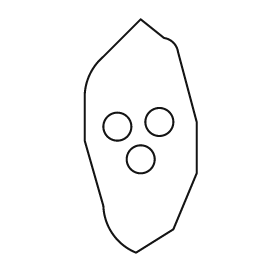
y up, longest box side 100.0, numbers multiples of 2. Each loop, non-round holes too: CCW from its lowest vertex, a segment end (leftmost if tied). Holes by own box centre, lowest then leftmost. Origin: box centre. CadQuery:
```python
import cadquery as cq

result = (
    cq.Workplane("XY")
    .moveTo(-2.0, -50.0)
    .lineTo(14.0, -40.0)
    .lineTo(24.0, -16.0)
    .lineTo(24.0, 6.0)
    .lineTo(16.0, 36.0)
    .threePointArc((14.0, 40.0), (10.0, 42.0))
    .lineTo(0.0, 50.0)
    .lineTo(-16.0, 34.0)
    .threePointArc((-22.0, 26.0), (-24.0, 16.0))
    .lineTo(-24.0, -2.0)
    .lineTo(-16.0, -30.0)
    .threePointArc((-12.0, -42.0), (-2.0, -50.0))
    .close()
    .moveTo(0.0, -10.0)
    .circle(6.0)
    .moveTo(-10.0, 4.0)
    .circle(6.0)
    .moveTo(8.0, 6.0)
    .circle(6.0)
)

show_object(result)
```